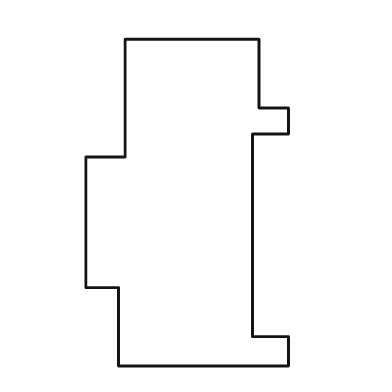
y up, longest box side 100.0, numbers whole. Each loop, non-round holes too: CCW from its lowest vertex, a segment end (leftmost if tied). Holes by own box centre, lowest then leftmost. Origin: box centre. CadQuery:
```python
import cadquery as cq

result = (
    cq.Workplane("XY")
    .moveTo(-21.0, -50.0)
    .lineTo(31.0, -50.0)
    .lineTo(31.0, -41.0)
    .lineTo(20.0, -41.0)
    .lineTo(20.0, 21.0)
    .lineTo(31.0, 21.0)
    .lineTo(31.0, 29.0)
    .lineTo(22.0, 29.0)
    .lineTo(22.0, 50.0)
    .lineTo(-19.0, 50.0)
    .lineTo(-19.0, 14.0)
    .lineTo(-31.0, 14.0)
    .lineTo(-31.0, -26.0)
    .lineTo(-21.0, -26.0)
    .close()
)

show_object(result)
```